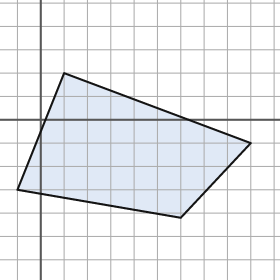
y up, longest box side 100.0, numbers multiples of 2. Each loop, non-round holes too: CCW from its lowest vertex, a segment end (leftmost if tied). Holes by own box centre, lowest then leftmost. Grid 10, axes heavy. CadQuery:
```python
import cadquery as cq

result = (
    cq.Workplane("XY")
    .moveTo(60.0, -42.0)
    .lineTo(90.0, -10.0)
    .lineTo(10.0, 20.0)
    .lineTo(-10.0, -30.0)
    .close()
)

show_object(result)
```